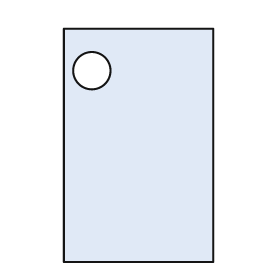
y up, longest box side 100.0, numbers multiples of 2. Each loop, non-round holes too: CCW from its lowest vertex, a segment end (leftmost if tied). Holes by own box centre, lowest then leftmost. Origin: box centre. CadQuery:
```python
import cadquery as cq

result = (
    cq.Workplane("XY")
    .moveTo(-32.0, -50.0)
    .lineTo(32.0, -50.0)
    .lineTo(32.0, 50.0)
    .lineTo(-32.0, 50.0)
    .close()
    .moveTo(-20.0, 32.0)
    .circle(8.0)
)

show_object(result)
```